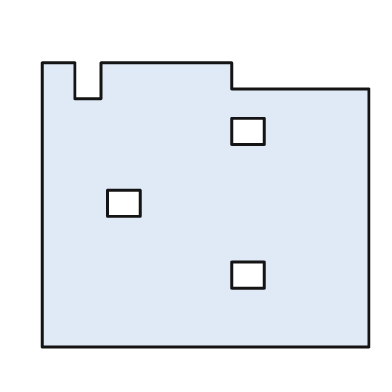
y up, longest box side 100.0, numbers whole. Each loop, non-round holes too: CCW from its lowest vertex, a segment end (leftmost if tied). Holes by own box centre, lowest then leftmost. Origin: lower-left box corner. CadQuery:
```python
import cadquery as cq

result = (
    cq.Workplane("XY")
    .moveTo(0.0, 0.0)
    .lineTo(100.0, 0.0)
    .lineTo(100.0, 79.0)
    .lineTo(58.0, 79.0)
    .lineTo(58.0, 87.0)
    .lineTo(18.0, 87.0)
    .lineTo(18.0, 76.0)
    .lineTo(10.0, 76.0)
    .lineTo(10.0, 87.0)
    .lineTo(0.0, 87.0)
    .close()
    .moveTo(58.0, 18.0)
    .lineTo(68.0, 18.0)
    .lineTo(68.0, 26.0)
    .lineTo(58.0, 26.0)
    .close()
    .moveTo(20.0, 40.0)
    .lineTo(30.0, 40.0)
    .lineTo(30.0, 48.0)
    .lineTo(20.0, 48.0)
    .close()
    .moveTo(58.0, 62.0)
    .lineTo(68.0, 62.0)
    .lineTo(68.0, 70.0)
    .lineTo(58.0, 70.0)
    .close()
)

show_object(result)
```